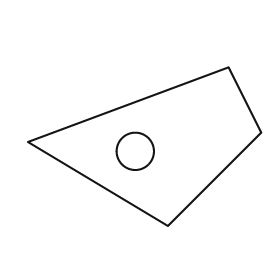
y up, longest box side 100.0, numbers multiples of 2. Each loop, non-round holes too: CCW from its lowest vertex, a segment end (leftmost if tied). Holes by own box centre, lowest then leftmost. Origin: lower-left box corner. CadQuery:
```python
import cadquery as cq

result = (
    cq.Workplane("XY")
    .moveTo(60.0, 0.0)
    .lineTo(100.0, 40.0)
    .lineTo(86.0, 68.0)
    .lineTo(0.0, 36.0)
    .close()
    .moveTo(46.0, 32.0)
    .circle(8.0)
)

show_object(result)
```